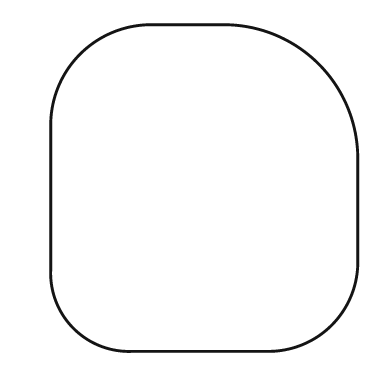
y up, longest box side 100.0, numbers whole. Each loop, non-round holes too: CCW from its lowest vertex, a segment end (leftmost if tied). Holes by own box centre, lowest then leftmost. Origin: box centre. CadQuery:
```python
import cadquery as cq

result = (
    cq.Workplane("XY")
    .moveTo(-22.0, -50.0)
    .lineTo(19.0, -50.0)
    .threePointArc((39.0, -42.0), (47.0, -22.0))
    .lineTo(47.0, 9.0)
    .threePointArc((35.0, 38.0), (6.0, 50.0))
    .lineTo(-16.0, 50.0)
    .threePointArc((-38.0, 41.0), (-47.0, 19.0))
    .lineTo(-47.0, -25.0)
    .threePointArc((-40.0, -43.0), (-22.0, -50.0))
    .close()
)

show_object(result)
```